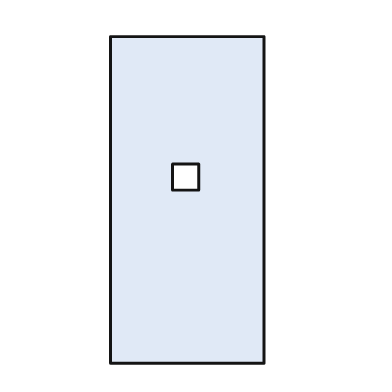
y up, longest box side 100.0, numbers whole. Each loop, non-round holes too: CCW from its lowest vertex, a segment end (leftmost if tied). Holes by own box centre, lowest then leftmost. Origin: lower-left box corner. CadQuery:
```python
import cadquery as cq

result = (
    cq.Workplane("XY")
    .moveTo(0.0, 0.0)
    .lineTo(47.0, 0.0)
    .lineTo(47.0, 100.0)
    .lineTo(0.0, 100.0)
    .close()
    .moveTo(19.0, 53.0)
    .lineTo(27.0, 53.0)
    .lineTo(27.0, 61.0)
    .lineTo(19.0, 61.0)
    .close()
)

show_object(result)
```